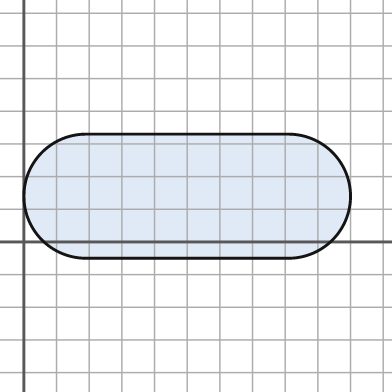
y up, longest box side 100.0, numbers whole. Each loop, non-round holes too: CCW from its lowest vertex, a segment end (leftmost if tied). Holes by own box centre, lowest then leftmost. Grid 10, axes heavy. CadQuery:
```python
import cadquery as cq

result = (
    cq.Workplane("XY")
    .moveTo(19.0, -5.0)
    .lineTo(81.0, -5.0)
    .threePointArc((100.0, 14.0), (81.0, 33.0))
    .lineTo(19.0, 33.0)
    .threePointArc((0.0, 14.0), (19.0, -5.0))
    .close()
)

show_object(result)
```